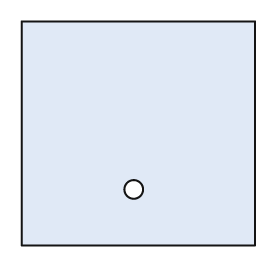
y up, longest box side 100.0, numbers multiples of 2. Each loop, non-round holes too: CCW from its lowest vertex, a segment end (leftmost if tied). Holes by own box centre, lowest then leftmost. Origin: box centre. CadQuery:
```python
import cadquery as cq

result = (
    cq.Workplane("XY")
    .moveTo(-50.0, -48.0)
    .lineTo(50.0, -48.0)
    .lineTo(50.0, 48.0)
    .lineTo(-50.0, 48.0)
    .close()
    .moveTo(-2.0, -24.0)
    .circle(4.0)
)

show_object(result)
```